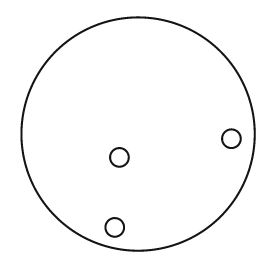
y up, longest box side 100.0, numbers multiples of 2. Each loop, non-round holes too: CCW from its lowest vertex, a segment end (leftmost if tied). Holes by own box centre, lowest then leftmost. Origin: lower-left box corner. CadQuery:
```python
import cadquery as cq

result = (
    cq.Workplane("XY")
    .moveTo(50.0, 50.0)
    .circle(50.0)
    .moveTo(40.0, 10.0)
    .circle(4.0)
    .moveTo(42.0, 40.0)
    .circle(4.0)
    .moveTo(90.0, 48.0)
    .circle(4.0)
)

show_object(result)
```